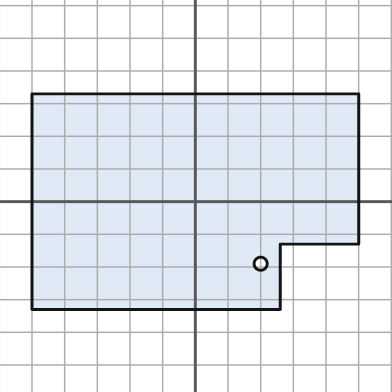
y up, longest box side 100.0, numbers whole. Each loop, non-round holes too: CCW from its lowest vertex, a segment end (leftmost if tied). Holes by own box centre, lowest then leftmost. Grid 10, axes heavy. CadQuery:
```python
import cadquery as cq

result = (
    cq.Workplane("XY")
    .moveTo(-50.0, -33.0)
    .lineTo(26.0, -33.0)
    .lineTo(26.0, -13.0)
    .lineTo(50.0, -13.0)
    .lineTo(50.0, 33.0)
    .lineTo(-50.0, 33.0)
    .close()
    .moveTo(20.0, -19.0)
    .circle(2.0)
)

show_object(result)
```